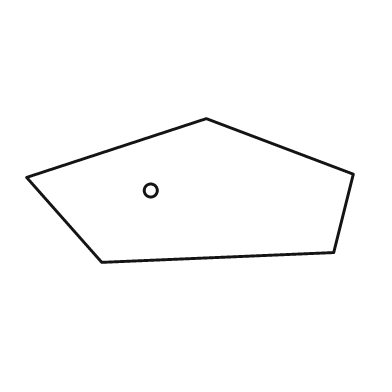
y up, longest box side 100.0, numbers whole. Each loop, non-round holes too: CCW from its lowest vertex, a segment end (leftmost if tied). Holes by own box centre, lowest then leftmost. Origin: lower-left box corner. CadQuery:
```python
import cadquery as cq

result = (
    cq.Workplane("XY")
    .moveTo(23.0, 0.0)
    .lineTo(94.0, 3.0)
    .lineTo(100.0, 27.0)
    .lineTo(55.0, 44.0)
    .lineTo(0.0, 26.0)
    .close()
    .moveTo(38.0, 22.0)
    .circle(2.0)
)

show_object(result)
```